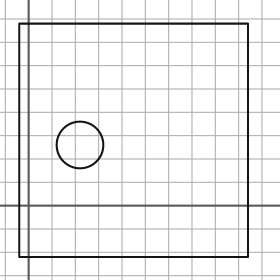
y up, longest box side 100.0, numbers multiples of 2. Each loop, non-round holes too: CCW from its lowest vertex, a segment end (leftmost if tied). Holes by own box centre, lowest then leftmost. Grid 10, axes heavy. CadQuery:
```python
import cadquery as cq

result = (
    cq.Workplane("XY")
    .moveTo(-4.0, -22.0)
    .lineTo(94.0, -22.0)
    .lineTo(94.0, 78.0)
    .lineTo(-4.0, 78.0)
    .close()
    .moveTo(22.0, 26.0)
    .circle(10.0)
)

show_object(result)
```